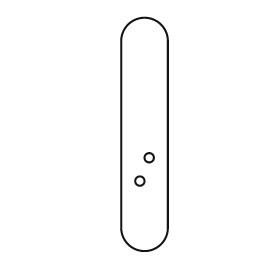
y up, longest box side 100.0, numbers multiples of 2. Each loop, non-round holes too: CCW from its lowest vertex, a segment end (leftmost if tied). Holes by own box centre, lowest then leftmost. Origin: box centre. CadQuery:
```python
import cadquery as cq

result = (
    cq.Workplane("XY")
    .moveTo(-10.0, -40.0)
    .threePointArc((0.0, -50.0), (10.0, -40.0))
    .lineTo(10.0, 40.0)
    .threePointArc((0.0, 50.0), (-10.0, 40.0))
    .close()
    .moveTo(-2.0, -20.0)
    .circle(2.0)
    .moveTo(2.0, -10.0)
    .circle(2.0)
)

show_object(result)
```